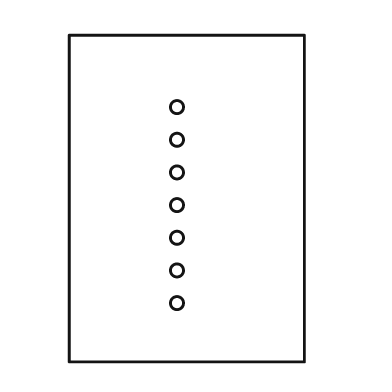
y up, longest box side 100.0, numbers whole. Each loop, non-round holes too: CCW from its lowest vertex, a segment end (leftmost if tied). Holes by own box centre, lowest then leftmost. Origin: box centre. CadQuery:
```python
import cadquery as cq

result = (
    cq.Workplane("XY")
    .moveTo(-36.0, -50.0)
    .lineTo(36.0, -50.0)
    .lineTo(36.0, 50.0)
    .lineTo(-36.0, 50.0)
    .close()
    .moveTo(-3.0, -32.0)
    .circle(2.0)
    .moveTo(-3.0, -22.0)
    .circle(2.0)
    .moveTo(-3.0, -12.0)
    .circle(2.0)
    .moveTo(-3.0, -2.0)
    .circle(2.0)
    .moveTo(-3.0, 8.0)
    .circle(2.0)
    .moveTo(-3.0, 18.0)
    .circle(2.0)
    .moveTo(-3.0, 28.0)
    .circle(2.0)
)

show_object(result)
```